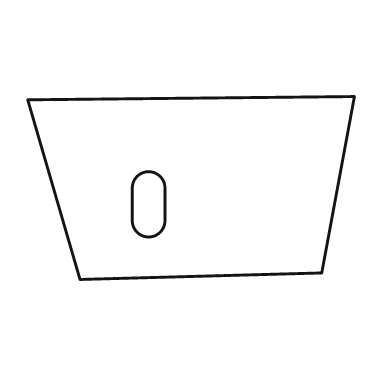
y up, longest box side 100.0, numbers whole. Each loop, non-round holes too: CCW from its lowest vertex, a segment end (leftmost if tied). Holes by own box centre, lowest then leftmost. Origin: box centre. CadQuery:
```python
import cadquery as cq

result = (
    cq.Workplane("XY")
    .moveTo(-34.0, -28.0)
    .lineTo(40.0, -26.0)
    .lineTo(50.0, 28.0)
    .lineTo(-50.0, 27.0)
    .close()
    .moveTo(-18.0, -10.0)
    .threePointArc((-13.0, -15.0), (-8.0, -10.0))
    .lineTo(-8.0, 0.0)
    .threePointArc((-13.0, 5.0), (-18.0, 0.0))
    .close()
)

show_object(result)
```